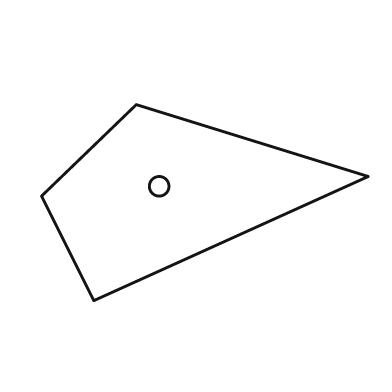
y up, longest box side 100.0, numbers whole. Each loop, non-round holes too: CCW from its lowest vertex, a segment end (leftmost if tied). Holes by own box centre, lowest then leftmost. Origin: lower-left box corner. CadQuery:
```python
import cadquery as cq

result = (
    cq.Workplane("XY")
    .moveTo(16.0, 0.0)
    .lineTo(100.0, 38.0)
    .lineTo(29.0, 60.0)
    .lineTo(0.0, 32.0)
    .close()
    .moveTo(36.0, 35.0)
    .circle(3.0)
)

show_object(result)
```